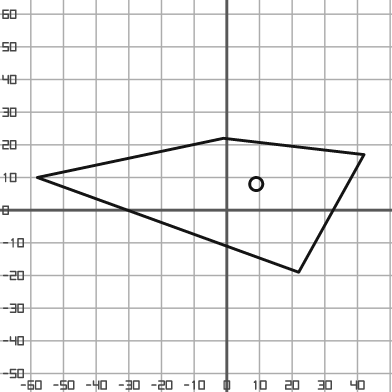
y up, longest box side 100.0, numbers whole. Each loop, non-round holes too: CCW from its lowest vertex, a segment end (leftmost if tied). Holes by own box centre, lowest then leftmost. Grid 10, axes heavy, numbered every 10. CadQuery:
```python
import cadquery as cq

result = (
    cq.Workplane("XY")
    .moveTo(22.0, -19.0)
    .lineTo(42.0, 17.0)
    .lineTo(-1.0, 22.0)
    .lineTo(-58.0, 10.0)
    .close()
    .moveTo(9.0, 8.0)
    .circle(2.0)
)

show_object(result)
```